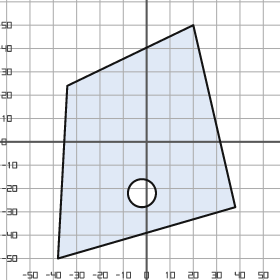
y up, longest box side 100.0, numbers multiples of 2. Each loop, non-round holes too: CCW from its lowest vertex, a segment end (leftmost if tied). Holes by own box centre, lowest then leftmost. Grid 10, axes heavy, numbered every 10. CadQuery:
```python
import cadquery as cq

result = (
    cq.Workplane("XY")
    .moveTo(-38.0, -50.0)
    .lineTo(38.0, -28.0)
    .lineTo(20.0, 50.0)
    .lineTo(-34.0, 24.0)
    .close()
    .moveTo(-2.0, -22.0)
    .circle(6.0)
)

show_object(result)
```